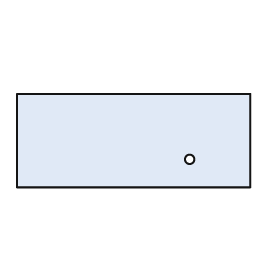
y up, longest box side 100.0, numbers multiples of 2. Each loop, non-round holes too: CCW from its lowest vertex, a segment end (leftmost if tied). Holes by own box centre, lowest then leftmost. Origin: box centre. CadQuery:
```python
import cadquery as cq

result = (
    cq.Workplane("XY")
    .moveTo(-50.0, -20.0)
    .lineTo(50.0, -20.0)
    .lineTo(50.0, 20.0)
    .lineTo(-50.0, 20.0)
    .close()
    .moveTo(24.0, -8.0)
    .circle(2.0)
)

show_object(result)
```